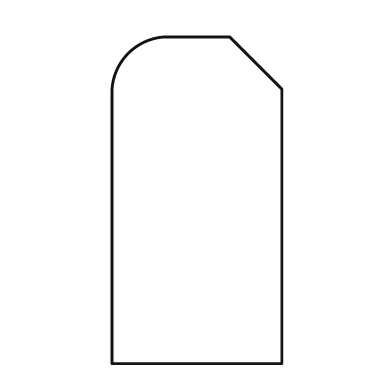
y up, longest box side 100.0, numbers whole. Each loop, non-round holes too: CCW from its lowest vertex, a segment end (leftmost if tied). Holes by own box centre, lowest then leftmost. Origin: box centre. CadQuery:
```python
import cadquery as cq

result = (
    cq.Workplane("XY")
    .moveTo(-26.0, -50.0)
    .lineTo(26.0, -50.0)
    .lineTo(26.0, 34.0)
    .lineTo(10.0, 50.0)
    .lineTo(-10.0, 50.0)
    .threePointArc((-21.0, 45.0), (-26.0, 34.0))
    .close()
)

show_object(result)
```